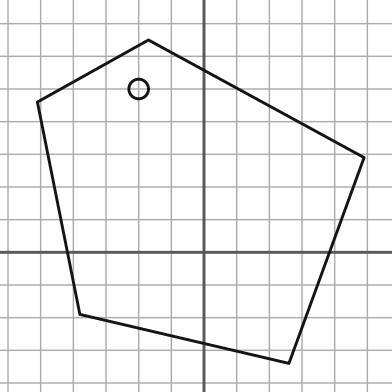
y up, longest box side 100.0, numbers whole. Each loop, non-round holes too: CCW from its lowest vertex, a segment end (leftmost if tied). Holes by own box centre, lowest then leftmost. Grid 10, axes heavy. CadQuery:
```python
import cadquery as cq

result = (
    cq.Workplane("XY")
    .moveTo(26.0, -34.0)
    .lineTo(49.0, 29.0)
    .lineTo(-17.0, 65.0)
    .lineTo(-51.0, 46.0)
    .lineTo(-38.0, -19.0)
    .close()
    .moveTo(-20.0, 50.0)
    .circle(3.0)
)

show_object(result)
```